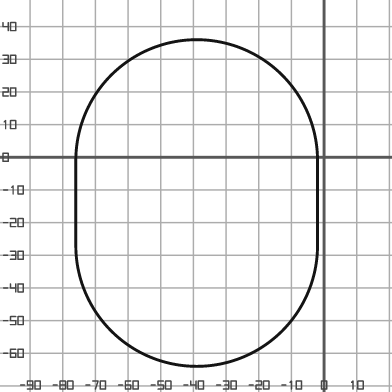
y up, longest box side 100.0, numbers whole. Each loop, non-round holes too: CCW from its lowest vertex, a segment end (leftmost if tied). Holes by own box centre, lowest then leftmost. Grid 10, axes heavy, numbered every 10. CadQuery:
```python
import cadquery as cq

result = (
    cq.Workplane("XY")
    .moveTo(-76.0, -27.0)
    .threePointArc((-39.0, -64.0), (-2.0, -27.0))
    .lineTo(-2.0, -1.0)
    .threePointArc((-39.0, 36.0), (-76.0, -1.0))
    .close()
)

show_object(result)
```